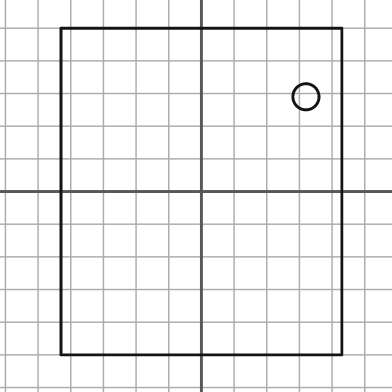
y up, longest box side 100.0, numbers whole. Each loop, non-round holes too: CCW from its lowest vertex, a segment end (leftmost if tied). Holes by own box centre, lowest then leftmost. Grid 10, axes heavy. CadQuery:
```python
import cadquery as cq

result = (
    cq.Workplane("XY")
    .moveTo(-43.0, -50.0)
    .lineTo(43.0, -50.0)
    .lineTo(43.0, 50.0)
    .lineTo(-43.0, 50.0)
    .close()
    .moveTo(32.0, 29.0)
    .circle(4.0)
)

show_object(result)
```